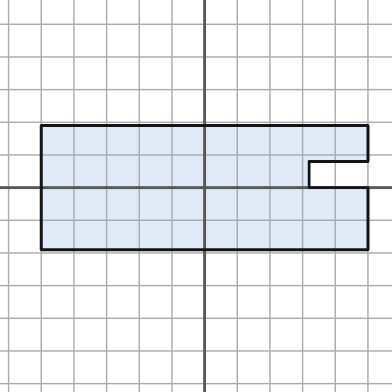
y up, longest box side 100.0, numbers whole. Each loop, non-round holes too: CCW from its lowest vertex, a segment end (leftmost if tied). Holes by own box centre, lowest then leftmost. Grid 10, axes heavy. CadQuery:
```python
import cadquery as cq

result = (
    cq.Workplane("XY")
    .moveTo(-50.0, -19.0)
    .lineTo(50.0, -19.0)
    .lineTo(50.0, 0.0)
    .lineTo(32.0, 0.0)
    .lineTo(32.0, 8.0)
    .lineTo(50.0, 8.0)
    .lineTo(50.0, 19.0)
    .lineTo(-50.0, 19.0)
    .close()
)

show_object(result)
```